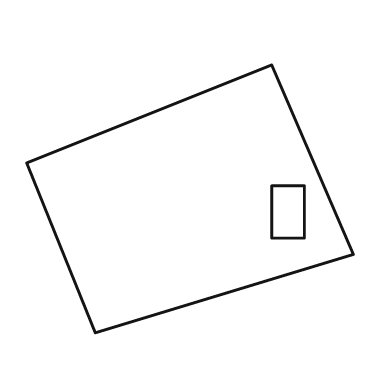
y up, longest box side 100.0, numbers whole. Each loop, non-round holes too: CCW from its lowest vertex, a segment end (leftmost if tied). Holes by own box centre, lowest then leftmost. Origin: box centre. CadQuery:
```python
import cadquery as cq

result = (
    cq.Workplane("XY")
    .moveTo(-29.0, -41.0)
    .lineTo(50.0, -17.0)
    .lineTo(25.0, 41.0)
    .lineTo(-50.0, 11.0)
    .close()
    .moveTo(25.0, -12.0)
    .lineTo(35.0, -12.0)
    .lineTo(35.0, 4.0)
    .lineTo(25.0, 4.0)
    .close()
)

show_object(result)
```